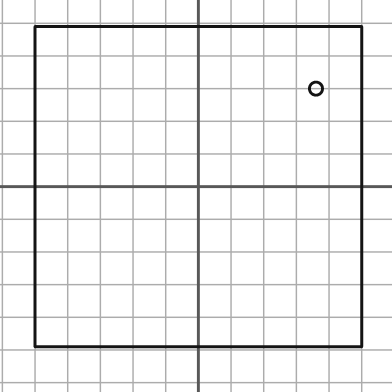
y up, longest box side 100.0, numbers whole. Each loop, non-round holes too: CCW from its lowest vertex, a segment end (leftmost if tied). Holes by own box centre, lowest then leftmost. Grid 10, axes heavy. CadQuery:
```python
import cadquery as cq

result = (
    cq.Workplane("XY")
    .moveTo(-50.0, -49.0)
    .lineTo(50.0, -49.0)
    .lineTo(50.0, 49.0)
    .lineTo(-50.0, 49.0)
    .close()
    .moveTo(36.0, 30.0)
    .circle(2.0)
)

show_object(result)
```